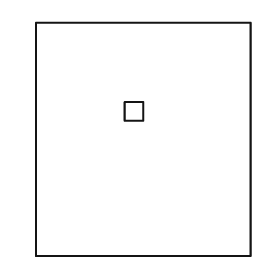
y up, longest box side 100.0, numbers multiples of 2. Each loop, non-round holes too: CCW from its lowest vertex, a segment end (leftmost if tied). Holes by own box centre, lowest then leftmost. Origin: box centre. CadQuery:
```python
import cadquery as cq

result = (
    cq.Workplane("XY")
    .moveTo(-46.0, -50.0)
    .lineTo(46.0, -50.0)
    .lineTo(46.0, 50.0)
    .lineTo(-46.0, 50.0)
    .close()
    .moveTo(-8.0, 8.0)
    .lineTo(0.0, 8.0)
    .lineTo(0.0, 16.0)
    .lineTo(-8.0, 16.0)
    .close()
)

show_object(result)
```